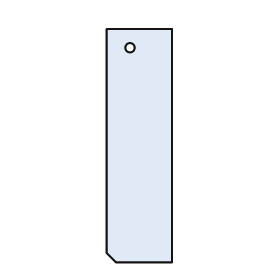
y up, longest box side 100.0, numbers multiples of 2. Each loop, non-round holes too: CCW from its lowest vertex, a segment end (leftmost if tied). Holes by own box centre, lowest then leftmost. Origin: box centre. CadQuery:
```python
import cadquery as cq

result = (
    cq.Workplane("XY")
    .moveTo(-10.0, -50.0)
    .lineTo(14.0, -50.0)
    .lineTo(14.0, 50.0)
    .lineTo(-14.0, 50.0)
    .lineTo(-14.0, -46.0)
    .close()
    .moveTo(-4.0, 42.0)
    .circle(2.0)
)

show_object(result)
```